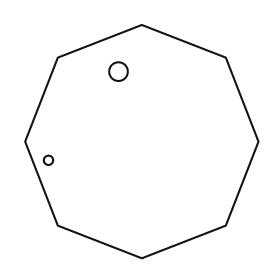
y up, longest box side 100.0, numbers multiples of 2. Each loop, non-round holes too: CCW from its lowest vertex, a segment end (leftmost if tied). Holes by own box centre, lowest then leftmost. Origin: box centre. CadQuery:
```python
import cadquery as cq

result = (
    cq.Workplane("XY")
    .moveTo(0.0, -50.0)
    .lineTo(36.0, -36.0)
    .lineTo(50.0, 0.0)
    .lineTo(36.0, 36.0)
    .lineTo(0.0, 50.0)
    .lineTo(-36.0, 36.0)
    .lineTo(-50.0, 0.0)
    .lineTo(-36.0, -36.0)
    .close()
    .moveTo(-40.0, -8.0)
    .circle(2.0)
    .moveTo(-10.0, 30.0)
    .circle(4.0)
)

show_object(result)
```